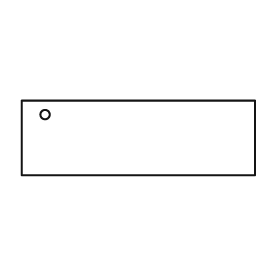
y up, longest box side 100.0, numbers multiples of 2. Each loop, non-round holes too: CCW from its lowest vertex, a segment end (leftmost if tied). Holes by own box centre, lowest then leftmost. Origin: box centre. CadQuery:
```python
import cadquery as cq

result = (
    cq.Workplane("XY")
    .moveTo(-50.0, -16.0)
    .lineTo(50.0, -16.0)
    .lineTo(50.0, 16.0)
    .lineTo(-50.0, 16.0)
    .close()
    .moveTo(-40.0, 10.0)
    .circle(2.0)
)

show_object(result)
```